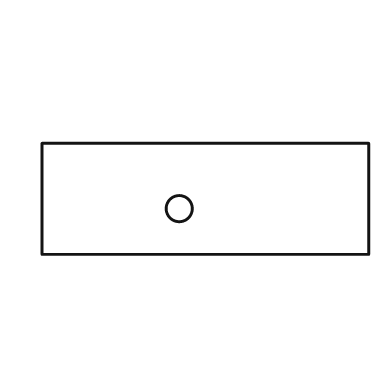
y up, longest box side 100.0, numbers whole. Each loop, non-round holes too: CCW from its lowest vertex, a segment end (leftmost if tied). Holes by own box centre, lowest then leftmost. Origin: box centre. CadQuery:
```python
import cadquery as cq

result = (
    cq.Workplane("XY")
    .moveTo(-50.0, -17.0)
    .lineTo(50.0, -17.0)
    .lineTo(50.0, 17.0)
    .lineTo(-50.0, 17.0)
    .close()
    .moveTo(-8.0, -3.0)
    .circle(4.0)
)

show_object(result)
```